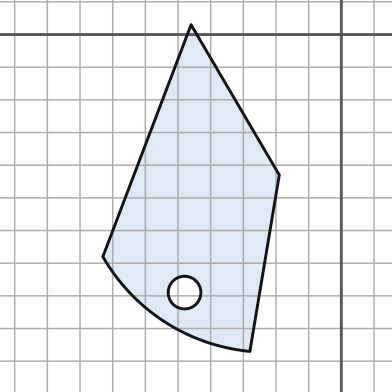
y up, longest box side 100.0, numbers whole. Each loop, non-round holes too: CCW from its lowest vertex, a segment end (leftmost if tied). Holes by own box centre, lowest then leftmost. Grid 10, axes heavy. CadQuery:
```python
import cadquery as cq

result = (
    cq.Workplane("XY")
    .moveTo(-28.0, -97.0)
    .lineTo(-19.0, -43.0)
    .lineTo(-46.0, 3.0)
    .lineTo(-73.0, -68.0)
    .threePointArc((-54.0, -88.0), (-28.0, -97.0))
    .close()
    .moveTo(-48.0, -79.0)
    .circle(5.0)
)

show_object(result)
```